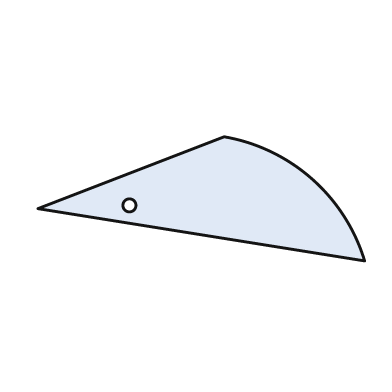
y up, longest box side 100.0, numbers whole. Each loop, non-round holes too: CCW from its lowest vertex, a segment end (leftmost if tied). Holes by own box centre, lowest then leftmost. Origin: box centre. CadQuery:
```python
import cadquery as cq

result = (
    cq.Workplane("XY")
    .moveTo(50.0, -19.0)
    .threePointArc((34.0, 6.0), (7.0, 19.0))
    .lineTo(-50.0, -3.0)
    .close()
    .moveTo(-22.0, -2.0)
    .circle(2.0)
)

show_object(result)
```